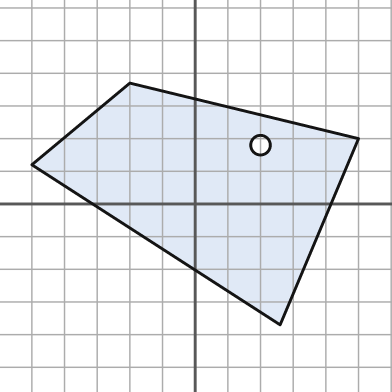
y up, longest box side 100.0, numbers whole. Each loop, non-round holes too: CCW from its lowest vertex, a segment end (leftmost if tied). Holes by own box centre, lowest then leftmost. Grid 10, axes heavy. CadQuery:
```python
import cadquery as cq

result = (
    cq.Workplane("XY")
    .moveTo(26.0, -37.0)
    .lineTo(50.0, 20.0)
    .lineTo(-20.0, 37.0)
    .lineTo(-50.0, 12.0)
    .close()
    .moveTo(20.0, 18.0)
    .circle(3.0)
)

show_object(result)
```